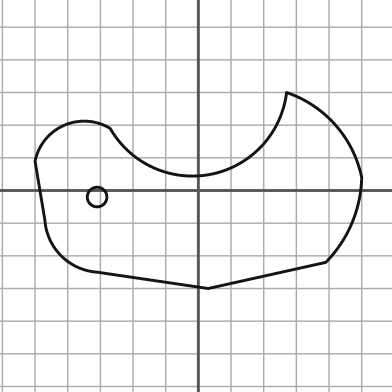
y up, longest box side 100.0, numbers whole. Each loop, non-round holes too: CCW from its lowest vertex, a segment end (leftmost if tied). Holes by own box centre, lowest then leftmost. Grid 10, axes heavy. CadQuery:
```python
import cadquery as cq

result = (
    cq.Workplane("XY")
    .moveTo(3.0, -30.0)
    .lineTo(39.0, -22.0)
    .threePointArc((47.0, -10.0), (50.0, 4.0))
    .threePointArc((42.0, 20.0), (27.0, 30.0))
    .threePointArc((4.0, 5.0), (-27.0, 19.0))
    .threePointArc((-41.0, 20.0), (-50.0, 9.0))
    .lineTo(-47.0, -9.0)
    .threePointArc((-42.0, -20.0), (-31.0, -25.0))
    .close()
    .moveTo(-31.0, -2.0)
    .circle(3.0)
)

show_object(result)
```